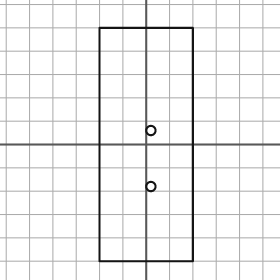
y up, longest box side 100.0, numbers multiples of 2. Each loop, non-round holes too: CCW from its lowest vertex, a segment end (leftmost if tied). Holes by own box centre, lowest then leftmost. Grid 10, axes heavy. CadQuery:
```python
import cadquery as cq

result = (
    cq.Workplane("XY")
    .moveTo(-20.0, -50.0)
    .lineTo(20.0, -50.0)
    .lineTo(20.0, 50.0)
    .lineTo(-20.0, 50.0)
    .close()
    .moveTo(2.0, -18.0)
    .circle(2.0)
    .moveTo(2.0, 6.0)
    .circle(2.0)
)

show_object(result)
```